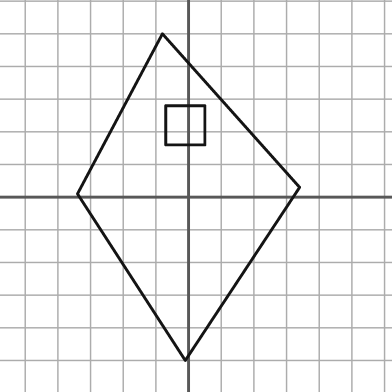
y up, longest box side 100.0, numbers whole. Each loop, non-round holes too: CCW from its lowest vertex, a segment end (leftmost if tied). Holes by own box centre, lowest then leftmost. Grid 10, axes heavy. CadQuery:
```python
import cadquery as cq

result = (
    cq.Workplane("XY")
    .moveTo(-1.0, -50.0)
    .lineTo(34.0, 3.0)
    .lineTo(-8.0, 50.0)
    .lineTo(-34.0, 1.0)
    .close()
    .moveTo(-7.0, 16.0)
    .lineTo(5.0, 16.0)
    .lineTo(5.0, 28.0)
    .lineTo(-7.0, 28.0)
    .close()
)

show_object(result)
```